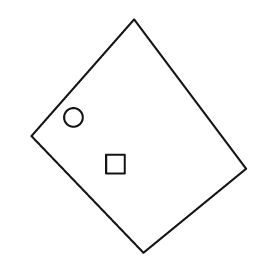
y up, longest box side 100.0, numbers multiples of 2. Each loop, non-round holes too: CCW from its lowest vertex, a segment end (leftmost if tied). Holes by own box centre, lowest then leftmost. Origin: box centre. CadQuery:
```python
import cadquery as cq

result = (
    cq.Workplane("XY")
    .moveTo(2.0, -50.0)
    .lineTo(46.0, -14.0)
    .lineTo(-2.0, 50.0)
    .lineTo(-46.0, 0.0)
    .close()
    .moveTo(-14.0, -16.0)
    .lineTo(-6.0, -16.0)
    .lineTo(-6.0, -8.0)
    .lineTo(-14.0, -8.0)
    .close()
    .moveTo(-28.0, 8.0)
    .circle(4.0)
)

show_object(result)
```